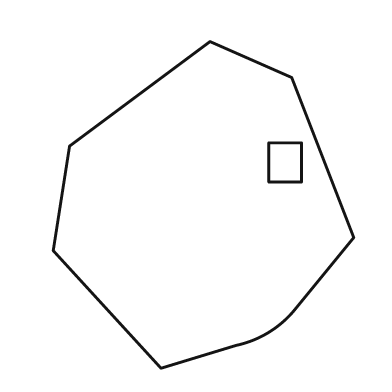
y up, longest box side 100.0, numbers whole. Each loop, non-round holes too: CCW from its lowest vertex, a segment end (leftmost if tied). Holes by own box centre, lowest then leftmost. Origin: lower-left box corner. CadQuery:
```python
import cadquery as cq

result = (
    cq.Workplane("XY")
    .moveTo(33.0, 0.0)
    .lineTo(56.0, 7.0)
    .threePointArc((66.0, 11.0), (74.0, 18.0))
    .lineTo(92.0, 40.0)
    .lineTo(73.0, 89.0)
    .lineTo(48.0, 100.0)
    .lineTo(5.0, 68.0)
    .lineTo(0.0, 36.0)
    .close()
    .moveTo(66.0, 57.0)
    .lineTo(76.0, 57.0)
    .lineTo(76.0, 69.0)
    .lineTo(66.0, 69.0)
    .close()
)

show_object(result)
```